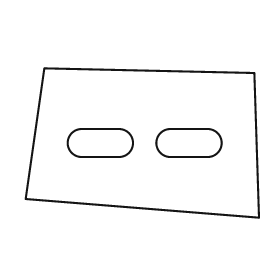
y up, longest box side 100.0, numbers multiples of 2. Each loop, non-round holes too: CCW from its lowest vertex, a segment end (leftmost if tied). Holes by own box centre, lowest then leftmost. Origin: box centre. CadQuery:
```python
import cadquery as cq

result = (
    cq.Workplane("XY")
    .moveTo(50.0, -32.0)
    .lineTo(48.0, 30.0)
    .lineTo(-42.0, 32.0)
    .lineTo(-50.0, -24.0)
    .close()
    .moveTo(-26.0, -6.0)
    .lineTo(-10.0, -6.0)
    .threePointArc((-4.0, 0.0), (-10.0, 6.0))
    .lineTo(-26.0, 6.0)
    .threePointArc((-32.0, 0.0), (-26.0, -6.0))
    .close()
    .moveTo(12.0, -6.0)
    .lineTo(28.0, -6.0)
    .threePointArc((34.0, 0.0), (28.0, 6.0))
    .lineTo(12.0, 6.0)
    .threePointArc((6.0, 0.0), (12.0, -6.0))
    .close()
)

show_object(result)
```